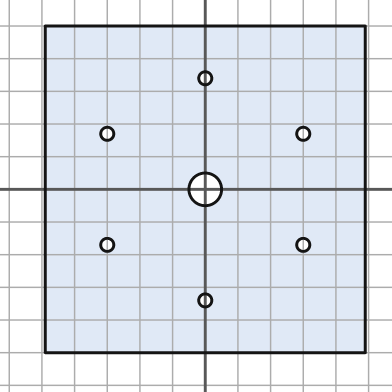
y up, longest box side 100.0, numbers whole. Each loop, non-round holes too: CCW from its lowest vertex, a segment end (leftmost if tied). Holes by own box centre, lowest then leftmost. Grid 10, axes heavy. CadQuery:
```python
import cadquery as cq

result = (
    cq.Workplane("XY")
    .moveTo(-49.0, -50.0)
    .lineTo(49.0, -50.0)
    .lineTo(49.0, 50.0)
    .lineTo(-49.0, 50.0)
    .close()
    .moveTo(0.0, -34.0)
    .circle(2.0)
    .moveTo(-30.0, -17.0)
    .circle(2.0)
    .moveTo(30.0, -17.0)
    .circle(2.0)
    .moveTo(0.0, 0.0)
    .circle(5.0)
    .moveTo(-30.0, 17.0)
    .circle(2.0)
    .moveTo(30.0, 17.0)
    .circle(2.0)
    .moveTo(0.0, 34.0)
    .circle(2.0)
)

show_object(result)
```